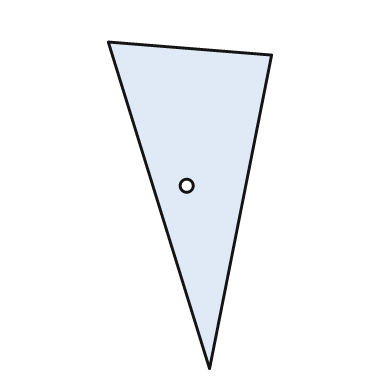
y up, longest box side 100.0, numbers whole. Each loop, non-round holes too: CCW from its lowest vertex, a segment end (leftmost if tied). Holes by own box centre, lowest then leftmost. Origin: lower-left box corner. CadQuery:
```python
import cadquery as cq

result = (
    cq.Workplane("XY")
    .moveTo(31.0, 0.0)
    .lineTo(50.0, 96.0)
    .lineTo(0.0, 100.0)
    .close()
    .moveTo(24.0, 56.0)
    .circle(2.0)
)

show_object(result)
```